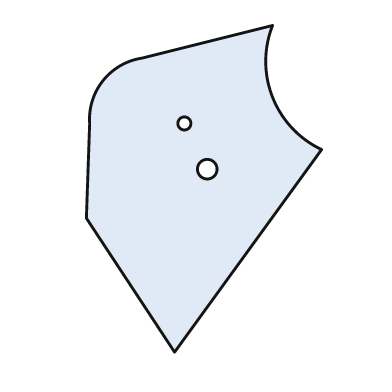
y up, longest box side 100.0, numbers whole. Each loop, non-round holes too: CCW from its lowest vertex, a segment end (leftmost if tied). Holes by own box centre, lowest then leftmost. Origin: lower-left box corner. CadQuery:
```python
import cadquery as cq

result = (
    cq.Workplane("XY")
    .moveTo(27.0, 0.0)
    .lineTo(72.0, 62.0)
    .threePointArc((57.0, 78.0), (57.0, 100.0))
    .lineTo(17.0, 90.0)
    .threePointArc((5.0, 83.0), (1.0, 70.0))
    .lineTo(0.0, 41.0)
    .close()
    .moveTo(37.0, 56.0)
    .circle(3.0)
    .moveTo(30.0, 70.0)
    .circle(2.0)
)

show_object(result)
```